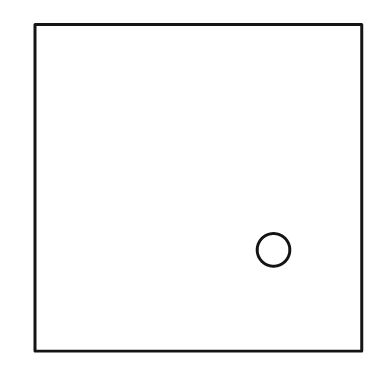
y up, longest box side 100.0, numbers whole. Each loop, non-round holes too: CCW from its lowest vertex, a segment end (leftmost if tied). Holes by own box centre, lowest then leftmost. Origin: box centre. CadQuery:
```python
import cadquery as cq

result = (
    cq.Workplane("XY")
    .moveTo(-50.0, -50.0)
    .lineTo(50.0, -50.0)
    .lineTo(50.0, 50.0)
    .lineTo(-50.0, 50.0)
    .close()
    .moveTo(23.0, -19.0)
    .circle(5.0)
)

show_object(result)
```